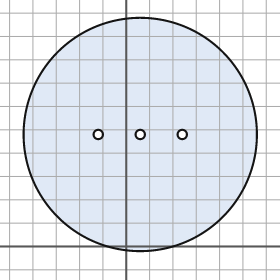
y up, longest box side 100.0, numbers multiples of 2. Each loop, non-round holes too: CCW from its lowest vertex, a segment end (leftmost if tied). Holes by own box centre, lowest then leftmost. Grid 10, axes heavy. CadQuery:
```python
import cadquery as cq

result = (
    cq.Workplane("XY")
    .moveTo(6.0, 48.0)
    .circle(50.0)
    .moveTo(-12.0, 48.0)
    .circle(2.0)
    .moveTo(6.0, 48.0)
    .circle(2.0)
    .moveTo(24.0, 48.0)
    .circle(2.0)
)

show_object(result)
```